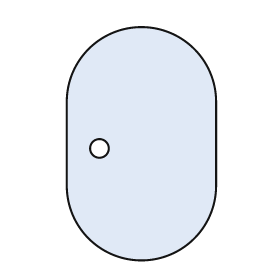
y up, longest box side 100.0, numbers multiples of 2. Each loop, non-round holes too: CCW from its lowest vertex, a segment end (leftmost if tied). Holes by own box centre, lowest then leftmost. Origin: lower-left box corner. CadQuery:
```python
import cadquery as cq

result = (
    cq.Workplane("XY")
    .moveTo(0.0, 32.0)
    .threePointArc((32.0, 0.0), (64.0, 32.0))
    .lineTo(64.0, 68.0)
    .threePointArc((32.0, 100.0), (0.0, 68.0))
    .close()
    .moveTo(14.0, 48.0)
    .circle(4.0)
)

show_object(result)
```